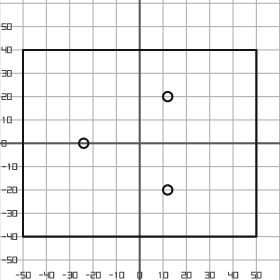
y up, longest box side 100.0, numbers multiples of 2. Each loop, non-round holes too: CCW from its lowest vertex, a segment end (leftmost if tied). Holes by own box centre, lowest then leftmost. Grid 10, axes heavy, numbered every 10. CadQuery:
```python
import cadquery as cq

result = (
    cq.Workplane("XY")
    .moveTo(-50.0, -40.0)
    .lineTo(50.0, -40.0)
    .lineTo(50.0, 40.0)
    .lineTo(-50.0, 40.0)
    .close()
    .moveTo(12.0, -20.0)
    .circle(2.0)
    .moveTo(-24.0, 0.0)
    .circle(2.0)
    .moveTo(12.0, 20.0)
    .circle(2.0)
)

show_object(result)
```